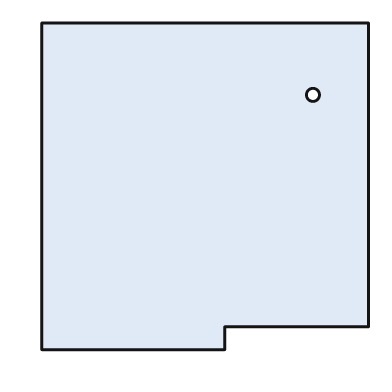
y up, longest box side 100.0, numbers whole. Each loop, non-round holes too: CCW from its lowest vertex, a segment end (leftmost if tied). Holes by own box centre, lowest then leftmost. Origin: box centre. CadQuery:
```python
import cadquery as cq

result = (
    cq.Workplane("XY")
    .moveTo(-50.0, -50.0)
    .lineTo(6.0, -50.0)
    .lineTo(6.0, -43.0)
    .lineTo(50.0, -43.0)
    .lineTo(50.0, 50.0)
    .lineTo(-50.0, 50.0)
    .close()
    .moveTo(33.0, 28.0)
    .circle(2.0)
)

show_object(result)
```